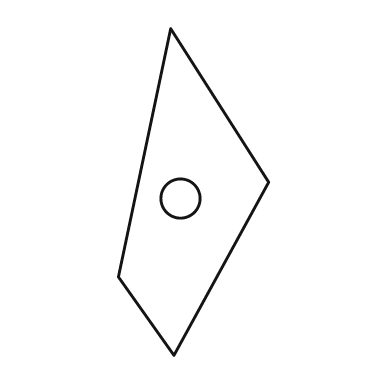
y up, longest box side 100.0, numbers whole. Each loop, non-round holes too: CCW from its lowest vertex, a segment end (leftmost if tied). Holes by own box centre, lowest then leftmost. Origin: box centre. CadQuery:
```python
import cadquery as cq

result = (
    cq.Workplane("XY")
    .moveTo(-6.0, -50.0)
    .lineTo(23.0, 3.0)
    .lineTo(-7.0, 50.0)
    .lineTo(-23.0, -26.0)
    .close()
    .moveTo(-4.0, -2.0)
    .circle(6.0)
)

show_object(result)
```